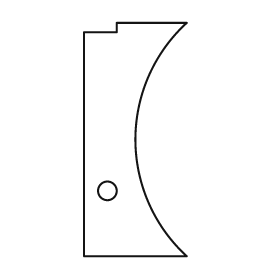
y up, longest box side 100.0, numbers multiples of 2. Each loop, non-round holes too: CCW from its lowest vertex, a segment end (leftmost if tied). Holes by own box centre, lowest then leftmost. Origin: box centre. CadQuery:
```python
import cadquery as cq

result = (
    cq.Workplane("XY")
    .moveTo(-22.0, -50.0)
    .lineTo(22.0, -50.0)
    .threePointArc((0.0, 0.0), (22.0, 50.0))
    .lineTo(-8.0, 50.0)
    .lineTo(-8.0, 46.0)
    .lineTo(-22.0, 46.0)
    .close()
    .moveTo(-12.0, -22.0)
    .circle(4.0)
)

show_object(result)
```